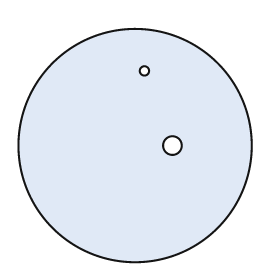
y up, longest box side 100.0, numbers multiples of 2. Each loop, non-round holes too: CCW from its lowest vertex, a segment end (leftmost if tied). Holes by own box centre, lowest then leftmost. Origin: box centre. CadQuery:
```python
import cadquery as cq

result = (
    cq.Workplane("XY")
    .moveTo(0.0, 0.0)
    .circle(50.0)
    .moveTo(16.0, 0.0)
    .circle(4.0)
    .moveTo(4.0, 32.0)
    .circle(2.0)
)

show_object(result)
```